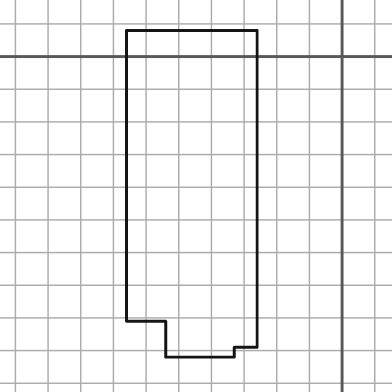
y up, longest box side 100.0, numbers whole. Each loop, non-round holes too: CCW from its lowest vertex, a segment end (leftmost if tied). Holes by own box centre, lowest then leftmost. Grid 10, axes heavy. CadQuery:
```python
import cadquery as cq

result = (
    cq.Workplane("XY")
    .moveTo(-54.0, -92.0)
    .lineTo(-33.0, -92.0)
    .lineTo(-33.0, -89.0)
    .lineTo(-26.0, -89.0)
    .lineTo(-26.0, 8.0)
    .lineTo(-66.0, 8.0)
    .lineTo(-66.0, -81.0)
    .lineTo(-54.0, -81.0)
    .close()
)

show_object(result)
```